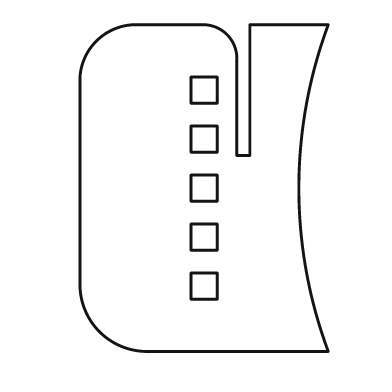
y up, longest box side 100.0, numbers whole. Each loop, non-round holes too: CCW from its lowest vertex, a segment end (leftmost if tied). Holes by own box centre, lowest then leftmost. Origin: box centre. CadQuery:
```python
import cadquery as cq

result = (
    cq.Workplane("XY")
    .moveTo(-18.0, -50.0)
    .lineTo(38.0, -50.0)
    .threePointArc((29.0, 0.0), (38.0, 50.0))
    .lineTo(14.0, 50.0)
    .lineTo(14.0, 10.0)
    .lineTo(10.0, 10.0)
    .lineTo(10.0, 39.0)
    .threePointArc((7.0, 47.0), (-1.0, 50.0))
    .lineTo(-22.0, 50.0)
    .threePointArc((-33.0, 45.0), (-38.0, 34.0))
    .lineTo(-38.0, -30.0)
    .threePointArc((-32.0, -44.0), (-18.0, -50.0))
    .close()
    .moveTo(-4.0, -34.0)
    .lineTo(4.0, -34.0)
    .lineTo(4.0, -26.0)
    .lineTo(-4.0, -26.0)
    .close()
    .moveTo(-4.0, -19.0)
    .lineTo(4.0, -19.0)
    .lineTo(4.0, -11.0)
    .lineTo(-4.0, -11.0)
    .close()
    .moveTo(-4.0, -4.0)
    .lineTo(4.0, -4.0)
    .lineTo(4.0, 4.0)
    .lineTo(-4.0, 4.0)
    .close()
    .moveTo(-4.0, 11.0)
    .lineTo(4.0, 11.0)
    .lineTo(4.0, 19.0)
    .lineTo(-4.0, 19.0)
    .close()
    .moveTo(-4.0, 26.0)
    .lineTo(4.0, 26.0)
    .lineTo(4.0, 34.0)
    .lineTo(-4.0, 34.0)
    .close()
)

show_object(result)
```